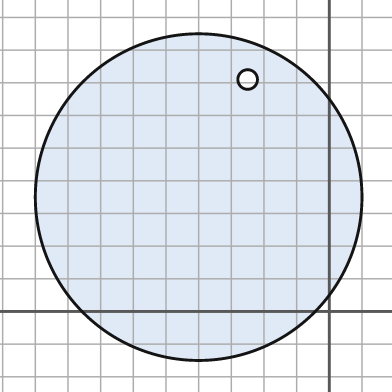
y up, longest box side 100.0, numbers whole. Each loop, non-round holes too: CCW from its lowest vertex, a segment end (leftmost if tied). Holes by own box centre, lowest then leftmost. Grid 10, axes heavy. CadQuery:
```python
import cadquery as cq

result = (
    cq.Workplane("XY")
    .moveTo(-40.0, 35.0)
    .circle(50.0)
    .moveTo(-25.0, 71.0)
    .circle(3.0)
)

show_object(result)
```